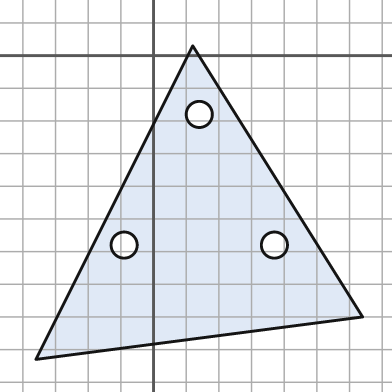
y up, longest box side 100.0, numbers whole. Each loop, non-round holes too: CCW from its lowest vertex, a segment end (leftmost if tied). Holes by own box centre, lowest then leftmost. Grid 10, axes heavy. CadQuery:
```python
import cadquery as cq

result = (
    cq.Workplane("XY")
    .moveTo(-36.0, -93.0)
    .lineTo(64.0, -80.0)
    .lineTo(12.0, 3.0)
    .close()
    .moveTo(-9.0, -58.0)
    .circle(4.0)
    .moveTo(37.0, -58.0)
    .circle(4.0)
    .moveTo(14.0, -18.0)
    .circle(4.0)
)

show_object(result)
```